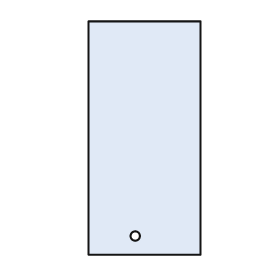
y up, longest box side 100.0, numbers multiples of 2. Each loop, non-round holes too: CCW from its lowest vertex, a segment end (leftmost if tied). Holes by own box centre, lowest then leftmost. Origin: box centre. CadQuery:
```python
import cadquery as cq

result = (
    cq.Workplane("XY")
    .moveTo(-24.0, -50.0)
    .lineTo(24.0, -50.0)
    .lineTo(24.0, 50.0)
    .lineTo(-24.0, 50.0)
    .close()
    .moveTo(-4.0, -42.0)
    .circle(2.0)
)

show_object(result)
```